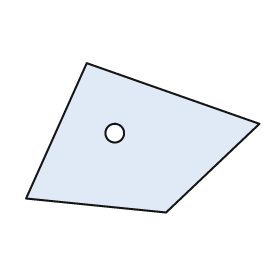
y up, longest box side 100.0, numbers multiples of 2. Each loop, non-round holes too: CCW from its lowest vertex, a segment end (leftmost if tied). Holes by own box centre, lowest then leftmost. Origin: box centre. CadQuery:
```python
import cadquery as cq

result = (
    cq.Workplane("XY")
    .moveTo(10.0, -32.0)
    .lineTo(50.0, 6.0)
    .lineTo(-24.0, 32.0)
    .lineTo(-50.0, -26.0)
    .close()
    .moveTo(-12.0, 2.0)
    .circle(4.0)
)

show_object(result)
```